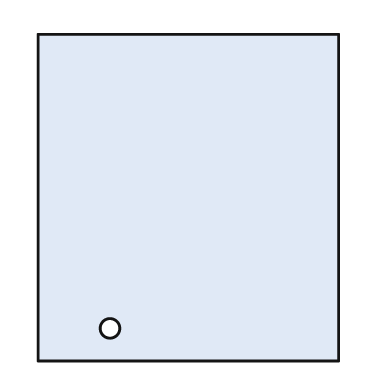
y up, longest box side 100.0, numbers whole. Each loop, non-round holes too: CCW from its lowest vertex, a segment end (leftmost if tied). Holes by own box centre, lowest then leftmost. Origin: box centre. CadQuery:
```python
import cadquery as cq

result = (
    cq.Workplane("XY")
    .moveTo(-46.0, -50.0)
    .lineTo(46.0, -50.0)
    .lineTo(46.0, 50.0)
    .lineTo(-46.0, 50.0)
    .close()
    .moveTo(-24.0, -40.0)
    .circle(3.0)
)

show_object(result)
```